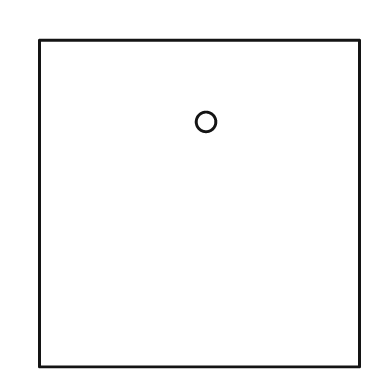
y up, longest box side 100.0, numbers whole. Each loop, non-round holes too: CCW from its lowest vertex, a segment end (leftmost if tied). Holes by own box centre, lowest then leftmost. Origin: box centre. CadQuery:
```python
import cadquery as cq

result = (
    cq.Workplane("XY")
    .moveTo(-49.0, -50.0)
    .lineTo(49.0, -50.0)
    .lineTo(49.0, 50.0)
    .lineTo(-49.0, 50.0)
    .close()
    .moveTo(2.0, 25.0)
    .circle(3.0)
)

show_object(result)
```